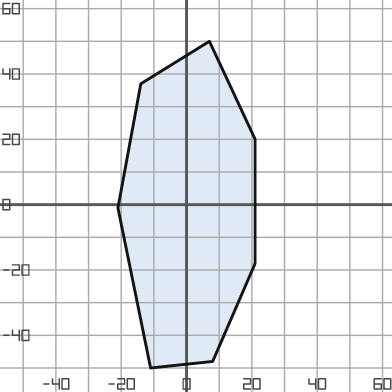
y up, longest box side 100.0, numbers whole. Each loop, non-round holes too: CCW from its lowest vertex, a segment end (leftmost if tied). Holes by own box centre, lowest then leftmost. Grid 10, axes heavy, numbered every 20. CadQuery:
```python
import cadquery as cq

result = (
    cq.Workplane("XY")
    .moveTo(-11.0, -50.0)
    .lineTo(8.0, -48.0)
    .lineTo(21.0, -18.0)
    .lineTo(21.0, 20.0)
    .lineTo(7.0, 50.0)
    .lineTo(-14.0, 37.0)
    .lineTo(-21.0, -1.0)
    .close()
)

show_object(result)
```